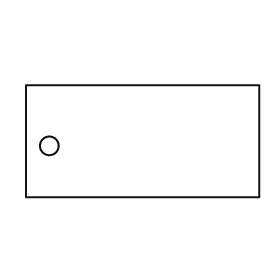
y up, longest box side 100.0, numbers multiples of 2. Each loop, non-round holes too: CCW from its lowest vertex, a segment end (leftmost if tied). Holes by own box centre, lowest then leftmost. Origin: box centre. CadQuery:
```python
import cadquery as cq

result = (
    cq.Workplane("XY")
    .moveTo(-50.0, -24.0)
    .lineTo(50.0, -24.0)
    .lineTo(50.0, 24.0)
    .lineTo(-50.0, 24.0)
    .close()
    .moveTo(-40.0, -2.0)
    .circle(4.0)
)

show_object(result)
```